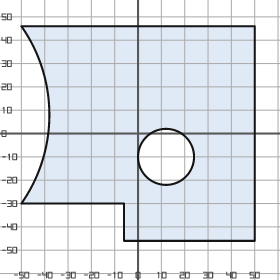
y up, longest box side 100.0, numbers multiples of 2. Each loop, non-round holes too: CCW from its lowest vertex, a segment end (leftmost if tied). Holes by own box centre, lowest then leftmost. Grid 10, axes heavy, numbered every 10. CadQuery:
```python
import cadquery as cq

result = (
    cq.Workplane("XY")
    .moveTo(-6.0, -46.0)
    .lineTo(50.0, -46.0)
    .lineTo(50.0, 46.0)
    .lineTo(-50.0, 46.0)
    .threePointArc((-38.0, 8.0), (-50.0, -30.0))
    .lineTo(-6.0, -30.0)
    .close()
    .moveTo(12.0, -10.0)
    .circle(12.0)
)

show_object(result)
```